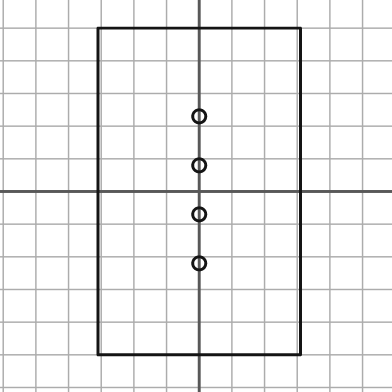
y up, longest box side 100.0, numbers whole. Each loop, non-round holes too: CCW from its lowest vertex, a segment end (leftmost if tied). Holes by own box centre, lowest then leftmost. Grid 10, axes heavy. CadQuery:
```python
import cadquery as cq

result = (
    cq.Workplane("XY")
    .moveTo(-31.0, -50.0)
    .lineTo(31.0, -50.0)
    .lineTo(31.0, 50.0)
    .lineTo(-31.0, 50.0)
    .close()
    .moveTo(0.0, -22.0)
    .circle(2.0)
    .moveTo(0.0, -7.0)
    .circle(2.0)
    .moveTo(0.0, 8.0)
    .circle(2.0)
    .moveTo(0.0, 23.0)
    .circle(2.0)
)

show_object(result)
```